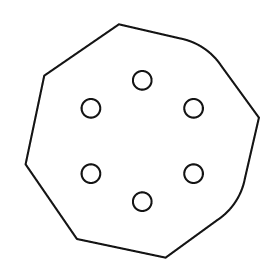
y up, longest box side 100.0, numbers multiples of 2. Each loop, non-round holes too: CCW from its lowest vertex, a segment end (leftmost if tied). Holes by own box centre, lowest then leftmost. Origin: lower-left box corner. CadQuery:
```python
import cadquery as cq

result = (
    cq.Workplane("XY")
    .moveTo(60.0, 0.0)
    .lineTo(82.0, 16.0)
    .threePointArc((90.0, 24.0), (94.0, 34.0))
    .lineTo(100.0, 60.0)
    .lineTo(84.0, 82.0)
    .threePointArc((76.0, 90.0), (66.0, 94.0))
    .lineTo(40.0, 100.0)
    .lineTo(8.0, 78.0)
    .lineTo(0.0, 40.0)
    .lineTo(22.0, 8.0)
    .close()
    .moveTo(50.0, 24.0)
    .circle(4.0)
    .moveTo(28.0, 36.0)
    .circle(4.0)
    .moveTo(72.0, 36.0)
    .circle(4.0)
    .moveTo(28.0, 64.0)
    .circle(4.0)
    .moveTo(72.0, 64.0)
    .circle(4.0)
    .moveTo(50.0, 76.0)
    .circle(4.0)
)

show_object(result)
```